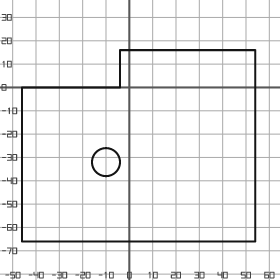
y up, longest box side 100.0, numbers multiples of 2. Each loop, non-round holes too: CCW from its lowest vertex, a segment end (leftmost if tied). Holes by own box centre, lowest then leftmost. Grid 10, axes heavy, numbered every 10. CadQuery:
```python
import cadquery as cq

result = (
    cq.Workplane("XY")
    .moveTo(-46.0, -66.0)
    .lineTo(54.0, -66.0)
    .lineTo(54.0, 16.0)
    .lineTo(-4.0, 16.0)
    .lineTo(-4.0, 0.0)
    .lineTo(-46.0, 0.0)
    .close()
    .moveTo(-10.0, -32.0)
    .circle(6.0)
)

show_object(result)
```